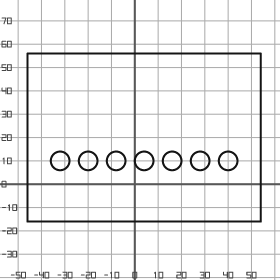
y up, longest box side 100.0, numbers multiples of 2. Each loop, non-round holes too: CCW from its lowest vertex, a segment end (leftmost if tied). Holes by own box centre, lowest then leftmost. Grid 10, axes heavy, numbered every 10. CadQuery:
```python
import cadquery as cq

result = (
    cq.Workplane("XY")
    .moveTo(-46.0, -16.0)
    .lineTo(54.0, -16.0)
    .lineTo(54.0, 56.0)
    .lineTo(-46.0, 56.0)
    .close()
    .moveTo(-32.0, 10.0)
    .circle(4.0)
    .moveTo(-20.0, 10.0)
    .circle(4.0)
    .moveTo(-8.0, 10.0)
    .circle(4.0)
    .moveTo(4.0, 10.0)
    .circle(4.0)
    .moveTo(16.0, 10.0)
    .circle(4.0)
    .moveTo(28.0, 10.0)
    .circle(4.0)
    .moveTo(40.0, 10.0)
    .circle(4.0)
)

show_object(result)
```